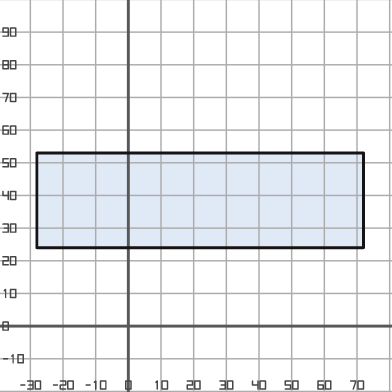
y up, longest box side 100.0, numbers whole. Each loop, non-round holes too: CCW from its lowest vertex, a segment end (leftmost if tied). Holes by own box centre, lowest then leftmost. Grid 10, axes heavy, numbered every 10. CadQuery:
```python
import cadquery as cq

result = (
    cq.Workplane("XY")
    .moveTo(-28.0, 24.0)
    .lineTo(72.0, 24.0)
    .lineTo(72.0, 53.0)
    .lineTo(-28.0, 53.0)
    .close()
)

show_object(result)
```